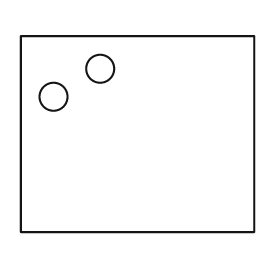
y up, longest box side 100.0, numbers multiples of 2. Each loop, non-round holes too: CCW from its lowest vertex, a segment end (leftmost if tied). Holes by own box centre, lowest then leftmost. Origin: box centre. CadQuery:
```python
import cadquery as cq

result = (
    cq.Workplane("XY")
    .moveTo(-50.0, -42.0)
    .lineTo(50.0, -42.0)
    .lineTo(50.0, 42.0)
    .lineTo(-50.0, 42.0)
    .close()
    .moveTo(-36.0, 16.0)
    .circle(6.0)
    .moveTo(-16.0, 28.0)
    .circle(6.0)
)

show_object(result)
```